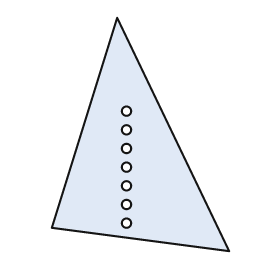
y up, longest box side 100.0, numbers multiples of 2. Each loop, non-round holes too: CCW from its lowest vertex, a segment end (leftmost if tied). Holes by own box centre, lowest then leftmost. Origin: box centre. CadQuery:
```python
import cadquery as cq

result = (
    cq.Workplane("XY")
    .moveTo(38.0, -50.0)
    .lineTo(-10.0, 50.0)
    .lineTo(-38.0, -40.0)
    .close()
    .moveTo(-6.0, -38.0)
    .circle(2.0)
    .moveTo(-6.0, -30.0)
    .circle(2.0)
    .moveTo(-6.0, -22.0)
    .circle(2.0)
    .moveTo(-6.0, -14.0)
    .circle(2.0)
    .moveTo(-6.0, -6.0)
    .circle(2.0)
    .moveTo(-6.0, 2.0)
    .circle(2.0)
    .moveTo(-6.0, 10.0)
    .circle(2.0)
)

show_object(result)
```